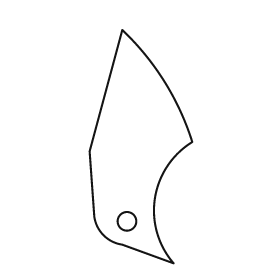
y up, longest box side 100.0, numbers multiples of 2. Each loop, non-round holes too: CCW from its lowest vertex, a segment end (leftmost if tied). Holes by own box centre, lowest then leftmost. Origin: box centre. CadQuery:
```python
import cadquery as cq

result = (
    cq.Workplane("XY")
    .moveTo(14.0, -50.0)
    .threePointArc((6.0, -22.0), (22.0, 2.0))
    .threePointArc((10.0, 28.0), (-8.0, 50.0))
    .lineTo(-22.0, -2.0)
    .lineTo(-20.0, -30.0)
    .threePointArc((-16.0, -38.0), (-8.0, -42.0))
    .close()
    .moveTo(-6.0, -32.0)
    .circle(4.0)
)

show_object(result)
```